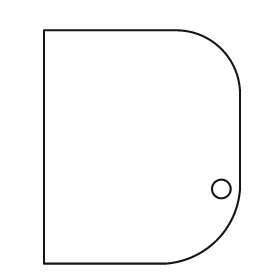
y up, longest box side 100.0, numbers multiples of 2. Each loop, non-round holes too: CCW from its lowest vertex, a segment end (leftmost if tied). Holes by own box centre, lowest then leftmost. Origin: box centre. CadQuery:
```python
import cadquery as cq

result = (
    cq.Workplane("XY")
    .moveTo(-42.0, -50.0)
    .lineTo(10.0, -50.0)
    .threePointArc((32.0, -40.0), (42.0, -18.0))
    .lineTo(42.0, 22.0)
    .threePointArc((34.0, 42.0), (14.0, 50.0))
    .lineTo(-42.0, 50.0)
    .close()
    .moveTo(34.0, -18.0)
    .circle(4.0)
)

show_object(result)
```